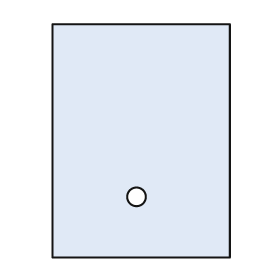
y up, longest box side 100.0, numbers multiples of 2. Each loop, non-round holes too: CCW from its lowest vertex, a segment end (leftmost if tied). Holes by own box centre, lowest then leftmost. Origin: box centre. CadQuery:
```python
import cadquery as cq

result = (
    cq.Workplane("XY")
    .moveTo(-38.0, -50.0)
    .lineTo(38.0, -50.0)
    .lineTo(38.0, 50.0)
    .lineTo(-38.0, 50.0)
    .close()
    .moveTo(-2.0, -24.0)
    .circle(4.0)
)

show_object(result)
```